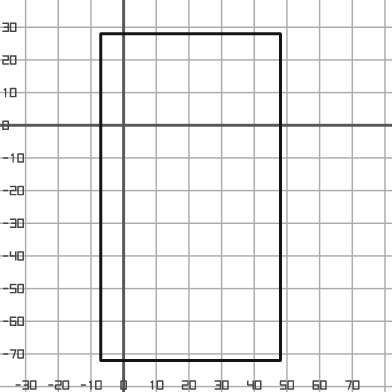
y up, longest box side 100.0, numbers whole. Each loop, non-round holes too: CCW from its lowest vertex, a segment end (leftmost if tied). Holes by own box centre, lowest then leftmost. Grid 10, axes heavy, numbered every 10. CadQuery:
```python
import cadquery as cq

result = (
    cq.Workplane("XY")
    .moveTo(-7.0, -72.0)
    .lineTo(48.0, -72.0)
    .lineTo(48.0, 28.0)
    .lineTo(-7.0, 28.0)
    .close()
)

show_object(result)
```